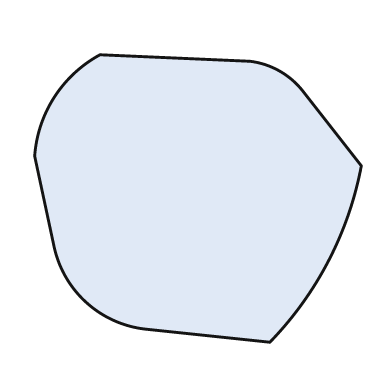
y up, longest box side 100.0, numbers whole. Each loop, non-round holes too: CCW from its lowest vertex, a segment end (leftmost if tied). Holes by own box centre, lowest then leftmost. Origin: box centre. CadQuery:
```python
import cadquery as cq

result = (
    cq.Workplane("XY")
    .moveTo(22.0, -44.0)
    .threePointArc((40.0, -19.0), (50.0, 10.0))
    .lineTo(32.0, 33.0)
    .threePointArc((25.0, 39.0), (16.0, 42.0))
    .lineTo(-30.0, 44.0)
    .threePointArc((-44.0, 31.0), (-50.0, 13.0))
    .lineTo(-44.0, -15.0)
    .threePointArc((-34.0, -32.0), (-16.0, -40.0))
    .close()
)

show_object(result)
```